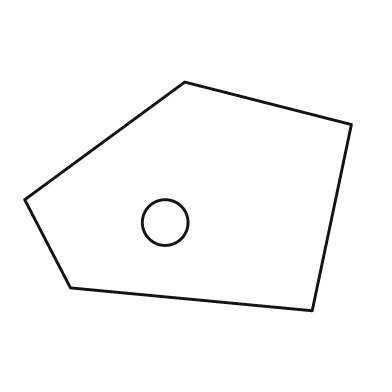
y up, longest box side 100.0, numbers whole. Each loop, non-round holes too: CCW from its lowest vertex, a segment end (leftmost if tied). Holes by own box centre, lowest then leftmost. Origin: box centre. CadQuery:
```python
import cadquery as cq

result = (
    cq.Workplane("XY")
    .moveTo(38.0, -35.0)
    .lineTo(50.0, 22.0)
    .lineTo(-1.0, 35.0)
    .lineTo(-50.0, -1.0)
    .lineTo(-36.0, -28.0)
    .close()
    .moveTo(-7.0, -8.0)
    .circle(7.0)
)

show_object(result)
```